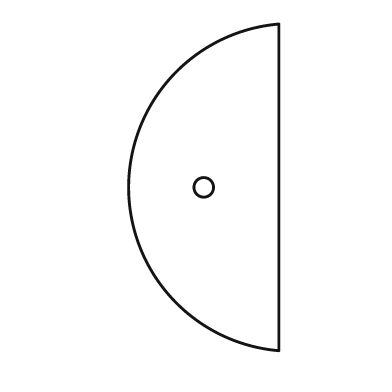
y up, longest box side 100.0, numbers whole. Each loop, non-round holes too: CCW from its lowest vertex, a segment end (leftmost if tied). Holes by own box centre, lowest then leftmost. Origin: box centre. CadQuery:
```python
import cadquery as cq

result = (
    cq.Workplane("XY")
    .moveTo(23.0, -50.0)
    .lineTo(23.0, 50.0)
    .threePointArc((-23.0, 0.0), (23.0, -50.0))
    .close()
    .moveTo(0.0, 0.0)
    .circle(3.0)
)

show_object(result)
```